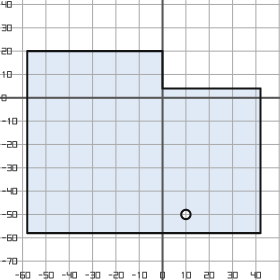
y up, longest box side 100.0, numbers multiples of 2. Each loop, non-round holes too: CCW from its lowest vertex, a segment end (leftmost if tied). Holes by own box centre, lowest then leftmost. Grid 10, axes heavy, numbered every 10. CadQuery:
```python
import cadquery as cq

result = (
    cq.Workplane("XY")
    .moveTo(-58.0, -58.0)
    .lineTo(42.0, -58.0)
    .lineTo(42.0, 4.0)
    .lineTo(0.0, 4.0)
    .lineTo(0.0, 20.0)
    .lineTo(-58.0, 20.0)
    .close()
    .moveTo(10.0, -50.0)
    .circle(2.0)
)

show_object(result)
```